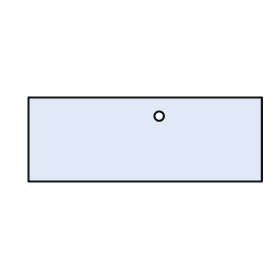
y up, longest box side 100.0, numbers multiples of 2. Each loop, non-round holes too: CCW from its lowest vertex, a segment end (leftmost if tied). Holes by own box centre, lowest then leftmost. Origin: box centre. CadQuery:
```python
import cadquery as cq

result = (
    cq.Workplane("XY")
    .moveTo(-50.0, -18.0)
    .lineTo(50.0, -18.0)
    .lineTo(50.0, 18.0)
    .lineTo(-50.0, 18.0)
    .close()
    .moveTo(6.0, 10.0)
    .circle(2.0)
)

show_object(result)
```